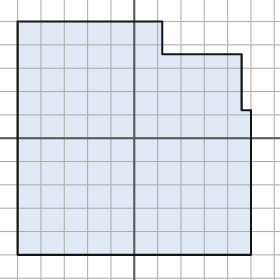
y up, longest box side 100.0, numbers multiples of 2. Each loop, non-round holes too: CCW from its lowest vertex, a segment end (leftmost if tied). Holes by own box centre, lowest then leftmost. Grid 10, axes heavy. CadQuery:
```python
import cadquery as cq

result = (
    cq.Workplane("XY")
    .moveTo(-50.0, -50.0)
    .lineTo(50.0, -50.0)
    .lineTo(50.0, 12.0)
    .lineTo(46.0, 12.0)
    .lineTo(46.0, 36.0)
    .lineTo(12.0, 36.0)
    .lineTo(12.0, 50.0)
    .lineTo(-50.0, 50.0)
    .close()
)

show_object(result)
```